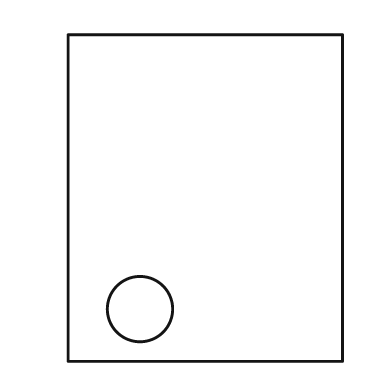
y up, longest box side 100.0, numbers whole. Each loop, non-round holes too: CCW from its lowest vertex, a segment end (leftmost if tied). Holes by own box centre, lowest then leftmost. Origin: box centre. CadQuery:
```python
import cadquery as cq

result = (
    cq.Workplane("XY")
    .moveTo(-42.0, -50.0)
    .lineTo(42.0, -50.0)
    .lineTo(42.0, 50.0)
    .lineTo(-42.0, 50.0)
    .close()
    .moveTo(-20.0, -34.0)
    .circle(10.0)
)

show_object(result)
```